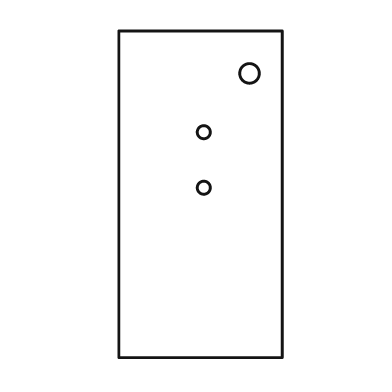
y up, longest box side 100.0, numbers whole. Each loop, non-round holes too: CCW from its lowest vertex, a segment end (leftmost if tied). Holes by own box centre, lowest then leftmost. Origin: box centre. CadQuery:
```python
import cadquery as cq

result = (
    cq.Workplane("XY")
    .moveTo(-25.0, -50.0)
    .lineTo(25.0, -50.0)
    .lineTo(25.0, 50.0)
    .lineTo(-25.0, 50.0)
    .close()
    .moveTo(1.0, 2.0)
    .circle(2.0)
    .moveTo(1.0, 19.0)
    .circle(2.0)
    .moveTo(15.0, 37.0)
    .circle(3.0)
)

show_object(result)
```